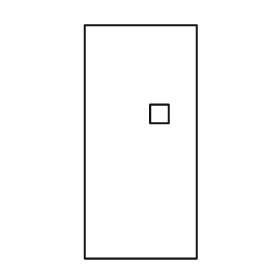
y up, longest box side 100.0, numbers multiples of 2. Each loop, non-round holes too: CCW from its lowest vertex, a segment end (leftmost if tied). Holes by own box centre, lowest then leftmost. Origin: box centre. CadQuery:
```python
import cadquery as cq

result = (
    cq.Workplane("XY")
    .moveTo(-24.0, -50.0)
    .lineTo(24.0, -50.0)
    .lineTo(24.0, 50.0)
    .lineTo(-24.0, 50.0)
    .close()
    .moveTo(4.0, 8.0)
    .lineTo(12.0, 8.0)
    .lineTo(12.0, 16.0)
    .lineTo(4.0, 16.0)
    .close()
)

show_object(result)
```